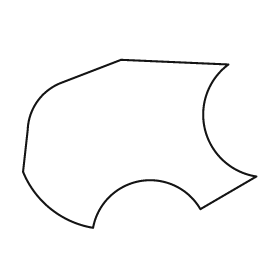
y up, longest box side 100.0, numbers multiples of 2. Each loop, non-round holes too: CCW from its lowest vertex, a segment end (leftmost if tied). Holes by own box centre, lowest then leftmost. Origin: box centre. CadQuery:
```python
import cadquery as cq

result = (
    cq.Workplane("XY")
    .moveTo(-20.0, -36.0)
    .threePointArc((0.0, -16.0), (26.0, -28.0))
    .lineTo(50.0, -14.0)
    .threePointArc((28.0, 6.0), (38.0, 34.0))
    .lineTo(-8.0, 36.0)
    .lineTo(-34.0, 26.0)
    .threePointArc((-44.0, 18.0), (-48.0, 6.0))
    .lineTo(-50.0, -12.0)
    .threePointArc((-38.0, -28.0), (-20.0, -36.0))
    .close()
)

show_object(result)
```